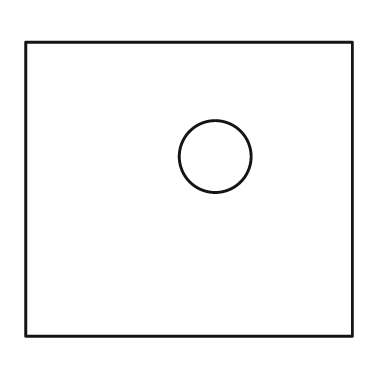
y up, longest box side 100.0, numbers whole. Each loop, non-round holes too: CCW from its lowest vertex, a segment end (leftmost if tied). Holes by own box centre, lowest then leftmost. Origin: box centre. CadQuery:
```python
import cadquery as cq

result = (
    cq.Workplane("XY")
    .moveTo(-50.0, -45.0)
    .lineTo(50.0, -45.0)
    .lineTo(50.0, 45.0)
    .lineTo(-50.0, 45.0)
    .close()
    .moveTo(8.0, 10.0)
    .circle(11.0)
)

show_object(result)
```